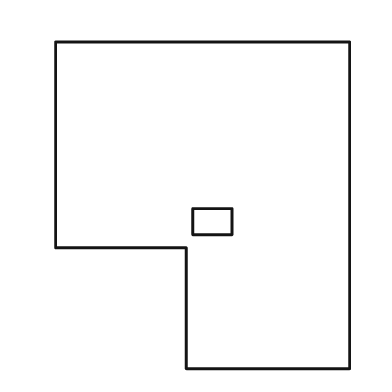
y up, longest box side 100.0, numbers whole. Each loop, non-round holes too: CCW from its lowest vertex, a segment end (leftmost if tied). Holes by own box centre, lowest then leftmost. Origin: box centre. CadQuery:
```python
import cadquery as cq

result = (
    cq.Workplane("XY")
    .moveTo(-5.0, -50.0)
    .lineTo(45.0, -50.0)
    .lineTo(45.0, 50.0)
    .lineTo(-45.0, 50.0)
    .lineTo(-45.0, -13.0)
    .lineTo(-5.0, -13.0)
    .close()
    .moveTo(-3.0, -9.0)
    .lineTo(9.0, -9.0)
    .lineTo(9.0, -1.0)
    .lineTo(-3.0, -1.0)
    .close()
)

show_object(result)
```